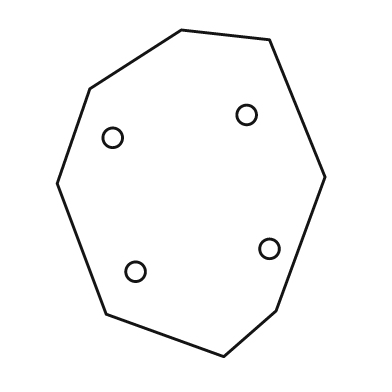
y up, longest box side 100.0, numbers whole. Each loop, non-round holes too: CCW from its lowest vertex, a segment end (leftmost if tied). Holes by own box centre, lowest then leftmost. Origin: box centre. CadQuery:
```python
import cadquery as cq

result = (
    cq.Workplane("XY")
    .moveTo(10.0, -50.0)
    .lineTo(26.0, -36.0)
    .lineTo(41.0, 5.0)
    .lineTo(24.0, 47.0)
    .lineTo(-3.0, 50.0)
    .lineTo(-31.0, 32.0)
    .lineTo(-41.0, 3.0)
    .lineTo(-26.0, -37.0)
    .close()
    .moveTo(-17.0, -24.0)
    .circle(3.0)
    .moveTo(24.0, -17.0)
    .circle(3.0)
    .moveTo(-24.0, 17.0)
    .circle(3.0)
    .moveTo(17.0, 24.0)
    .circle(3.0)
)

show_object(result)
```